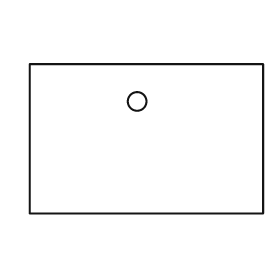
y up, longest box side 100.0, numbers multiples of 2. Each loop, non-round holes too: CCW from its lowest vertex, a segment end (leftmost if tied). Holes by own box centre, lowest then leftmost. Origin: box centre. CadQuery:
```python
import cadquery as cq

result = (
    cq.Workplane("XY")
    .moveTo(-50.0, -32.0)
    .lineTo(50.0, -32.0)
    .lineTo(50.0, 32.0)
    .lineTo(-50.0, 32.0)
    .close()
    .moveTo(-4.0, 16.0)
    .circle(4.0)
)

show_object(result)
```